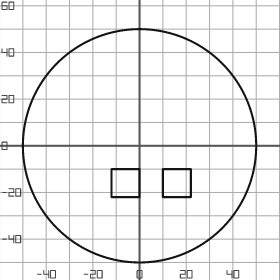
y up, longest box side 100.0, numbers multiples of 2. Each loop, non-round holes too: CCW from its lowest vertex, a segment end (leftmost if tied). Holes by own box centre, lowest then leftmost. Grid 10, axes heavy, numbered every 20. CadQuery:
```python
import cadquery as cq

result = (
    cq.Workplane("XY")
    .moveTo(0.0, 0.0)
    .circle(50.0)
    .moveTo(-12.0, -22.0)
    .lineTo(0.0, -22.0)
    .lineTo(0.0, -10.0)
    .lineTo(-12.0, -10.0)
    .close()
    .moveTo(10.0, -22.0)
    .lineTo(22.0, -22.0)
    .lineTo(22.0, -10.0)
    .lineTo(10.0, -10.0)
    .close()
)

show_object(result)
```